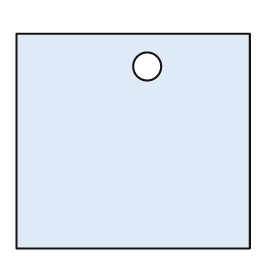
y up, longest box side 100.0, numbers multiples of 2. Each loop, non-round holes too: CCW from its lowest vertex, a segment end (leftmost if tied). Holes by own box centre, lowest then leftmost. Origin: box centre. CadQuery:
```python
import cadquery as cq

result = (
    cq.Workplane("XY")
    .moveTo(-50.0, -46.0)
    .lineTo(50.0, -46.0)
    .lineTo(50.0, 46.0)
    .lineTo(-50.0, 46.0)
    .close()
    .moveTo(6.0, 32.0)
    .circle(6.0)
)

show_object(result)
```